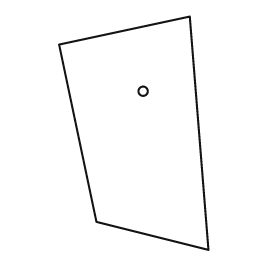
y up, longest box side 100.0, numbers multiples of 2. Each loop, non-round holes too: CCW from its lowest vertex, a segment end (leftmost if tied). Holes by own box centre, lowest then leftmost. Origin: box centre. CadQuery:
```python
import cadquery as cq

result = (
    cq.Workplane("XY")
    .moveTo(32.0, -50.0)
    .lineTo(24.0, 50.0)
    .lineTo(-32.0, 38.0)
    .lineTo(-16.0, -38.0)
    .close()
    .moveTo(4.0, 18.0)
    .circle(2.0)
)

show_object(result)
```